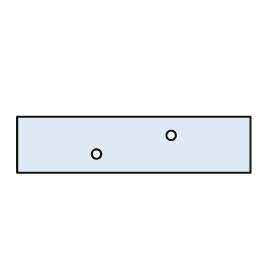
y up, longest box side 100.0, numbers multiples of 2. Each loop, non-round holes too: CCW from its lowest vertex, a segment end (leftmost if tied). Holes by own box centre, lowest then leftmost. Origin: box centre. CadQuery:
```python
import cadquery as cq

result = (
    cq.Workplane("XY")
    .moveTo(-50.0, -12.0)
    .lineTo(50.0, -12.0)
    .lineTo(50.0, 12.0)
    .lineTo(-50.0, 12.0)
    .close()
    .moveTo(-16.0, -4.0)
    .circle(2.0)
    .moveTo(16.0, 4.0)
    .circle(2.0)
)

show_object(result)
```